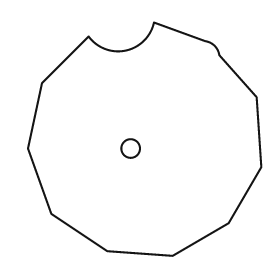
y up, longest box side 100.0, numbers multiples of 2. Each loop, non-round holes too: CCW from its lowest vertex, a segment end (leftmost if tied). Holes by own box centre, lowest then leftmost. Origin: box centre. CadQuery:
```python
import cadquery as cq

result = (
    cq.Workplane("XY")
    .moveTo(12.0, -50.0)
    .lineTo(36.0, -36.0)
    .lineTo(50.0, -12.0)
    .lineTo(48.0, 18.0)
    .lineTo(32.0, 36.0)
    .threePointArc((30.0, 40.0), (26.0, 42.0))
    .lineTo(4.0, 50.0)
    .threePointArc((-8.0, 38.0), (-24.0, 44.0))
    .lineTo(-44.0, 24.0)
    .lineTo(-50.0, -4.0)
    .lineTo(-40.0, -32.0)
    .lineTo(-16.0, -48.0)
    .close()
    .moveTo(-6.0, -4.0)
    .circle(4.0)
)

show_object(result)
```